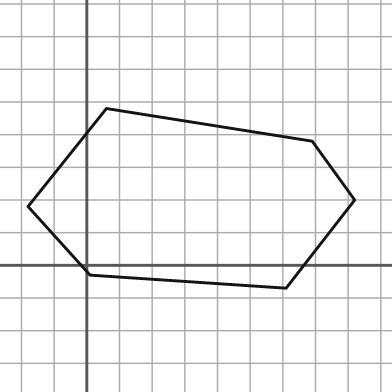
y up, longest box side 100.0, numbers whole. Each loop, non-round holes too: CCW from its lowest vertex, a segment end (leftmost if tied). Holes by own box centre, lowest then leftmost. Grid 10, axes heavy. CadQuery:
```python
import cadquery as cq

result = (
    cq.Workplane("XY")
    .moveTo(61.0, -7.0)
    .lineTo(82.0, 20.0)
    .lineTo(69.0, 38.0)
    .lineTo(6.0, 48.0)
    .lineTo(-18.0, 18.0)
    .lineTo(1.0, -3.0)
    .close()
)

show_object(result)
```